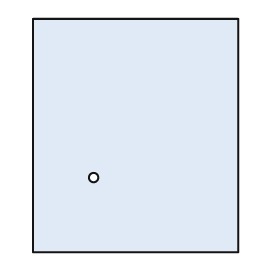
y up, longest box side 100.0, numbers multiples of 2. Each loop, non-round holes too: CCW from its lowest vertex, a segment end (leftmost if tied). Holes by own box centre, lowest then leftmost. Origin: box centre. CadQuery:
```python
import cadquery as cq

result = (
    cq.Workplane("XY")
    .moveTo(-44.0, -50.0)
    .lineTo(44.0, -50.0)
    .lineTo(44.0, 50.0)
    .lineTo(-44.0, 50.0)
    .close()
    .moveTo(-18.0, -18.0)
    .circle(2.0)
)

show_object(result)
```